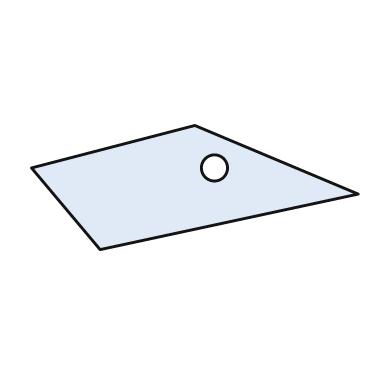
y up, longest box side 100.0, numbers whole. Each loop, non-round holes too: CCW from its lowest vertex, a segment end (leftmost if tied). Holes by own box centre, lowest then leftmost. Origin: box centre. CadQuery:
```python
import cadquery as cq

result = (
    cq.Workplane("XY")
    .moveTo(-29.0, -19.0)
    .lineTo(50.0, -2.0)
    .lineTo(0.0, 19.0)
    .lineTo(-50.0, 6.0)
    .close()
    .moveTo(6.0, 6.0)
    .circle(4.0)
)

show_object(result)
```